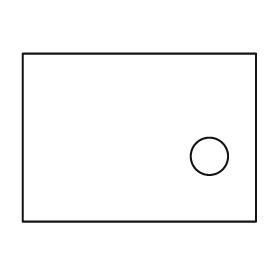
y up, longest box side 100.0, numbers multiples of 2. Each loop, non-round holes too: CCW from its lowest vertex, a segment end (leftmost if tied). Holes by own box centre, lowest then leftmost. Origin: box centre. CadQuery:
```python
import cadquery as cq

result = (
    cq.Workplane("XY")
    .moveTo(-50.0, -36.0)
    .lineTo(50.0, -36.0)
    .lineTo(50.0, 36.0)
    .lineTo(-50.0, 36.0)
    .close()
    .moveTo(30.0, -8.0)
    .circle(8.0)
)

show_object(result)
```